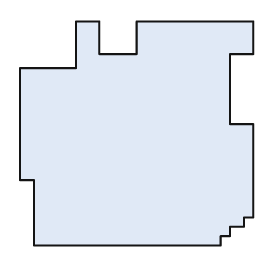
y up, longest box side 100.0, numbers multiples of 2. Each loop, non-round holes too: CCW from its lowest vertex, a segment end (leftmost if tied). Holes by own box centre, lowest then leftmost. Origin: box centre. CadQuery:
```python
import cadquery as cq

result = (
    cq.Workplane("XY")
    .moveTo(-44.0, -48.0)
    .lineTo(36.0, -48.0)
    .lineTo(36.0, -44.0)
    .lineTo(40.0, -44.0)
    .lineTo(40.0, -40.0)
    .lineTo(46.0, -40.0)
    .lineTo(46.0, -36.0)
    .lineTo(50.0, -36.0)
    .lineTo(50.0, 4.0)
    .lineTo(40.0, 4.0)
    .lineTo(40.0, 34.0)
    .lineTo(50.0, 34.0)
    .lineTo(50.0, 48.0)
    .lineTo(0.0, 48.0)
    .lineTo(0.0, 34.0)
    .lineTo(-16.0, 34.0)
    .lineTo(-16.0, 48.0)
    .lineTo(-26.0, 48.0)
    .lineTo(-26.0, 28.0)
    .lineTo(-50.0, 28.0)
    .lineTo(-50.0, -20.0)
    .lineTo(-44.0, -20.0)
    .close()
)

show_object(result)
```